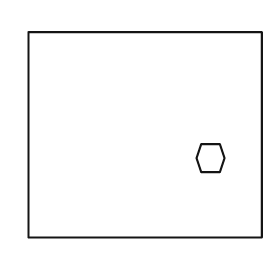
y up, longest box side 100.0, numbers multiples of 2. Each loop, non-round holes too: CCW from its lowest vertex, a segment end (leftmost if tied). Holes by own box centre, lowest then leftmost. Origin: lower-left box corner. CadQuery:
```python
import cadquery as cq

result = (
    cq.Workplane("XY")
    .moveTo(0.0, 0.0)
    .lineTo(100.0, 0.0)
    .lineTo(100.0, 88.0)
    .lineTo(0.0, 88.0)
    .close()
    .moveTo(74.0, 28.0)
    .lineTo(82.0, 28.0)
    .lineTo(84.0, 34.0)
    .lineTo(82.0, 40.0)
    .lineTo(74.0, 40.0)
    .lineTo(72.0, 34.0)
    .close()
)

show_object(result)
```